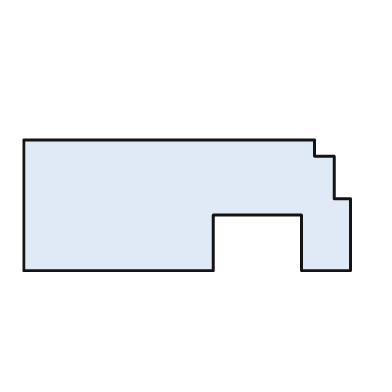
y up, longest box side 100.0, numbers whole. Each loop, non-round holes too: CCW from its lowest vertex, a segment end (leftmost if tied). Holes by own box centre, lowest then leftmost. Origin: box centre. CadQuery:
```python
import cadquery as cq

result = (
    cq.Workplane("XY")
    .moveTo(-50.0, -20.0)
    .lineTo(8.0, -20.0)
    .lineTo(8.0, -3.0)
    .lineTo(35.0, -3.0)
    .lineTo(35.0, -20.0)
    .lineTo(50.0, -20.0)
    .lineTo(50.0, 2.0)
    .lineTo(45.0, 2.0)
    .lineTo(45.0, 15.0)
    .lineTo(39.0, 15.0)
    .lineTo(39.0, 20.0)
    .lineTo(-50.0, 20.0)
    .close()
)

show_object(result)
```